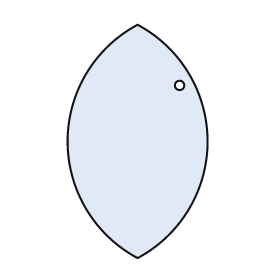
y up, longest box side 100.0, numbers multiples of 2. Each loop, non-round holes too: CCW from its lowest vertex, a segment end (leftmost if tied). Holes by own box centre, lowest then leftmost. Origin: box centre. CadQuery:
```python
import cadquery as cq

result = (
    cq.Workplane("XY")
    .moveTo(0.0, -50.0)
    .threePointArc((30.0, 0.0), (0.0, 50.0))
    .threePointArc((-30.0, 0.0), (0.0, -50.0))
    .close()
    .moveTo(18.0, 24.0)
    .circle(2.0)
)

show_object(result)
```